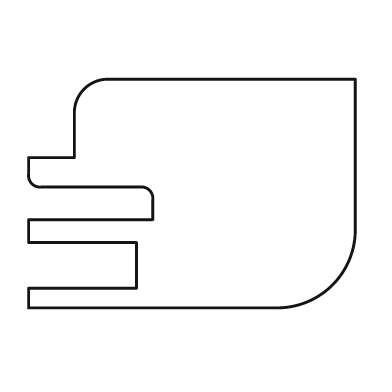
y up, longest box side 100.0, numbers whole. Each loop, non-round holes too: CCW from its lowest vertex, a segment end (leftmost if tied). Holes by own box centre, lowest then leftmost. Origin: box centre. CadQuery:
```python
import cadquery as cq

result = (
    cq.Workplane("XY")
    .moveTo(-50.0, -35.0)
    .lineTo(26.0, -35.0)
    .threePointArc((43.0, -28.0), (50.0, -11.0))
    .lineTo(50.0, 35.0)
    .lineTo(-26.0, 35.0)
    .threePointArc((-33.0, 32.0), (-36.0, 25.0))
    .lineTo(-36.0, 11.0)
    .lineTo(-50.0, 11.0)
    .lineTo(-50.0, 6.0)
    .threePointArc((-49.0, 3.0), (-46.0, 2.0))
    .lineTo(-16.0, 2.0)
    .threePointArc((-13.0, 1.0), (-12.0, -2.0))
    .lineTo(-12.0, -8.0)
    .lineTo(-50.0, -8.0)
    .lineTo(-50.0, -15.0)
    .lineTo(-17.0, -15.0)
    .lineTo(-17.0, -29.0)
    .lineTo(-50.0, -29.0)
    .close()
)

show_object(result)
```